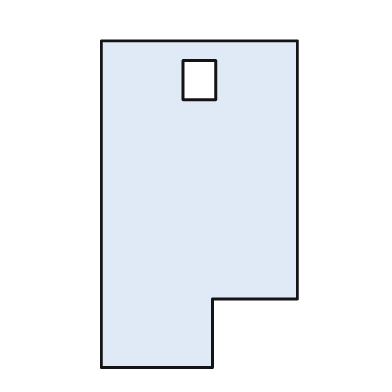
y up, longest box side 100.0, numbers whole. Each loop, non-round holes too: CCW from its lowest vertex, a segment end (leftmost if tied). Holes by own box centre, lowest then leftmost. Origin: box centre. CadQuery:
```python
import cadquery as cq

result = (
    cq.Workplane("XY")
    .moveTo(-30.0, -50.0)
    .lineTo(4.0, -50.0)
    .lineTo(4.0, -29.0)
    .lineTo(30.0, -29.0)
    .lineTo(30.0, 50.0)
    .lineTo(-30.0, 50.0)
    .close()
    .moveTo(-5.0, 32.0)
    .lineTo(5.0, 32.0)
    .lineTo(5.0, 44.0)
    .lineTo(-5.0, 44.0)
    .close()
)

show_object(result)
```